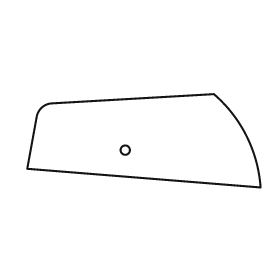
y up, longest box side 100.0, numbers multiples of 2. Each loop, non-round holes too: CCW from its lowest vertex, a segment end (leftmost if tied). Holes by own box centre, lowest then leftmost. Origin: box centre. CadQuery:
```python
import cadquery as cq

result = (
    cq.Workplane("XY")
    .moveTo(50.0, -20.0)
    .threePointArc((44.0, 2.0), (30.0, 20.0))
    .lineTo(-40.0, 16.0)
    .threePointArc((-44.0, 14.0), (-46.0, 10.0))
    .lineTo(-50.0, -12.0)
    .close()
    .moveTo(-8.0, -4.0)
    .circle(2.0)
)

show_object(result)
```